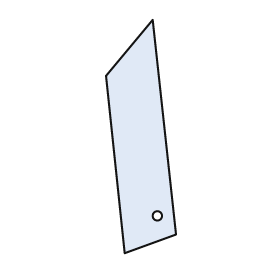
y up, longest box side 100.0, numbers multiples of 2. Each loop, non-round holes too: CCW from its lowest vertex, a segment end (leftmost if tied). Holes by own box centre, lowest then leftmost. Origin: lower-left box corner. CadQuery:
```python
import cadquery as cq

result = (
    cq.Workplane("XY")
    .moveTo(8.0, 0.0)
    .lineTo(30.0, 8.0)
    .lineTo(20.0, 100.0)
    .lineTo(0.0, 76.0)
    .close()
    .moveTo(22.0, 16.0)
    .circle(2.0)
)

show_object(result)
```